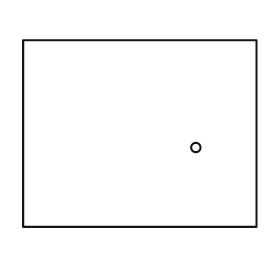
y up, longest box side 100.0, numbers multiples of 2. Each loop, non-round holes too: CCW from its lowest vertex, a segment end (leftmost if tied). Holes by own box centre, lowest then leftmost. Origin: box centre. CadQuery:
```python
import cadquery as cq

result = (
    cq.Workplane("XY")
    .moveTo(-50.0, -40.0)
    .lineTo(50.0, -40.0)
    .lineTo(50.0, 40.0)
    .lineTo(-50.0, 40.0)
    .close()
    .moveTo(24.0, -6.0)
    .circle(2.0)
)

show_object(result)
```